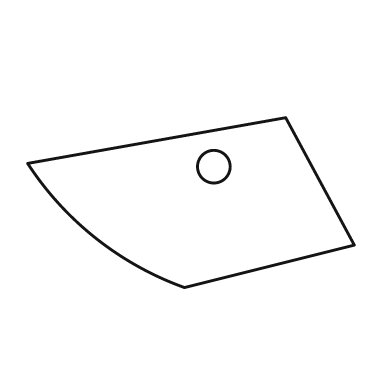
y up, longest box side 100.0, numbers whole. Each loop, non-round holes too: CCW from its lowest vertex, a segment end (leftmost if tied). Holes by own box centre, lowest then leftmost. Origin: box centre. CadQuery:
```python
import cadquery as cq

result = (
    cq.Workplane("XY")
    .moveTo(-2.0, -26.0)
    .lineTo(50.0, -13.0)
    .lineTo(29.0, 26.0)
    .lineTo(-50.0, 12.0)
    .threePointArc((-29.0, -11.0), (-2.0, -26.0))
    .close()
    .moveTo(7.0, 11.0)
    .circle(5.0)
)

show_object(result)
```